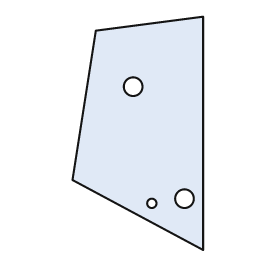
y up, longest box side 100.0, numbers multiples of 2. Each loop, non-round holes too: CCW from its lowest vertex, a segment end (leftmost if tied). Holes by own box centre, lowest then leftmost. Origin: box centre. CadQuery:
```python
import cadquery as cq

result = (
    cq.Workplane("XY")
    .moveTo(28.0, -50.0)
    .lineTo(28.0, 50.0)
    .lineTo(-18.0, 44.0)
    .lineTo(-28.0, -20.0)
    .close()
    .moveTo(6.0, -30.0)
    .circle(2.0)
    .moveTo(20.0, -28.0)
    .circle(4.0)
    .moveTo(-2.0, 20.0)
    .circle(4.0)
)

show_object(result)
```